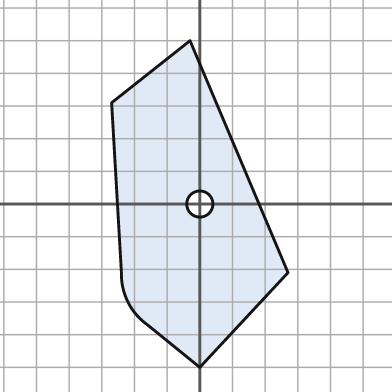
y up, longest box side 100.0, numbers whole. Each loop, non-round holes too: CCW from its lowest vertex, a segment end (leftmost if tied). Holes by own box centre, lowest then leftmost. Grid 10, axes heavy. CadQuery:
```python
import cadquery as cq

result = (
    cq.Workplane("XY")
    .moveTo(0.0, -50.0)
    .lineTo(27.0, -21.0)
    .lineTo(-3.0, 50.0)
    .lineTo(-27.0, 31.0)
    .lineTo(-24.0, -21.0)
    .threePointArc((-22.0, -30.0), (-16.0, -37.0))
    .close()
    .moveTo(0.0, 0.0)
    .circle(4.0)
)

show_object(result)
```